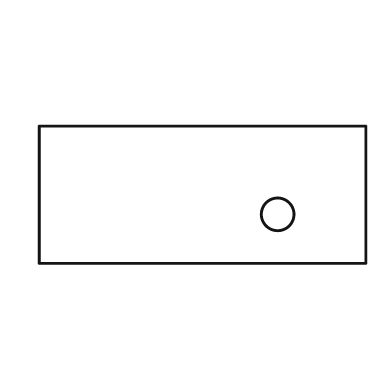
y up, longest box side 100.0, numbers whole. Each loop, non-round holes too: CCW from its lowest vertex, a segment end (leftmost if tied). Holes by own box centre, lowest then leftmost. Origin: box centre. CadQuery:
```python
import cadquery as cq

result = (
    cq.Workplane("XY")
    .moveTo(-50.0, -21.0)
    .lineTo(50.0, -21.0)
    .lineTo(50.0, 21.0)
    .lineTo(-50.0, 21.0)
    .close()
    .moveTo(23.0, -6.0)
    .circle(5.0)
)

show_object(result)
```